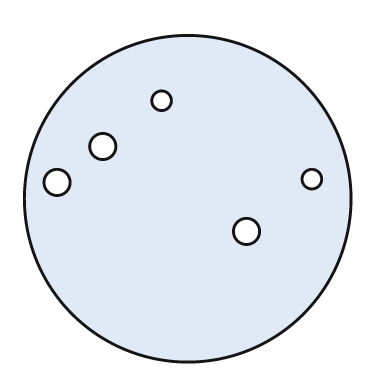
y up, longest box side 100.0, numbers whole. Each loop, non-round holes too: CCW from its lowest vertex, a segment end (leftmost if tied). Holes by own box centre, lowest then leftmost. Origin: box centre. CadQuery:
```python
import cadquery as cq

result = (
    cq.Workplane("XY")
    .moveTo(0.0, 0.0)
    .circle(50.0)
    .moveTo(18.0, -10.0)
    .circle(4.0)
    .moveTo(-40.0, 5.0)
    .circle(4.0)
    .moveTo(38.0, 6.0)
    .circle(3.0)
    .moveTo(-26.0, 16.0)
    .circle(4.0)
    .moveTo(-8.0, 30.0)
    .circle(3.0)
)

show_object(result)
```